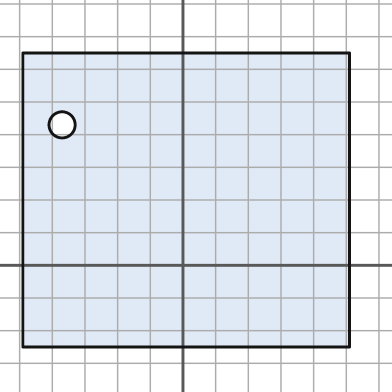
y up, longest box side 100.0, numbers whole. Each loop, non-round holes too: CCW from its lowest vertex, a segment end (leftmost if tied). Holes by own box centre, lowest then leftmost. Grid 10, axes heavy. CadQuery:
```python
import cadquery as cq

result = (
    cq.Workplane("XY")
    .moveTo(-49.0, -25.0)
    .lineTo(51.0, -25.0)
    .lineTo(51.0, 65.0)
    .lineTo(-49.0, 65.0)
    .close()
    .moveTo(-37.0, 43.0)
    .circle(4.0)
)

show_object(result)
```